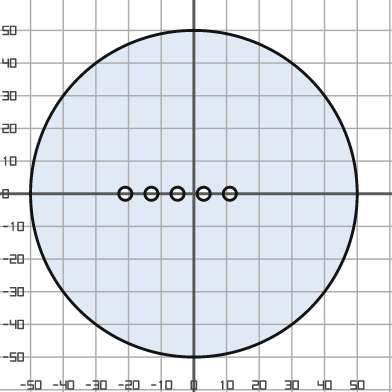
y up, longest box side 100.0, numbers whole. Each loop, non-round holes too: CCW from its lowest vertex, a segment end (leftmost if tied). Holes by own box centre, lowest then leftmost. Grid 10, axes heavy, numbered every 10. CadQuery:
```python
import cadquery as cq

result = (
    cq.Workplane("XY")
    .moveTo(0.0, 0.0)
    .circle(50.0)
    .moveTo(-21.0, 0.0)
    .circle(2.0)
    .moveTo(-13.0, 0.0)
    .circle(2.0)
    .moveTo(-5.0, 0.0)
    .circle(2.0)
    .moveTo(3.0, 0.0)
    .circle(2.0)
    .moveTo(11.0, 0.0)
    .circle(2.0)
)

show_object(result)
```